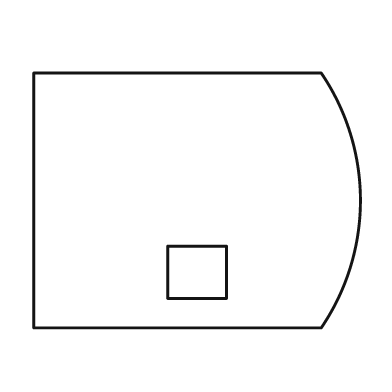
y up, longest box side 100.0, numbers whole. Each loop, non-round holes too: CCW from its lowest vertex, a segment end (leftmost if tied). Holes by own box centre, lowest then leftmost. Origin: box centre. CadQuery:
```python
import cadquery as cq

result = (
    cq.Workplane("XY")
    .moveTo(-50.0, -39.0)
    .lineTo(38.0, -39.0)
    .threePointArc((50.0, 0.0), (38.0, 39.0))
    .lineTo(-50.0, 39.0)
    .close()
    .moveTo(-9.0, -30.0)
    .lineTo(9.0, -30.0)
    .lineTo(9.0, -14.0)
    .lineTo(-9.0, -14.0)
    .close()
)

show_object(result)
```